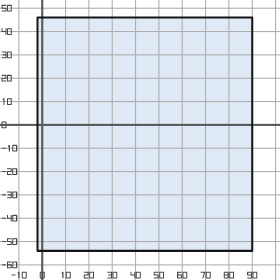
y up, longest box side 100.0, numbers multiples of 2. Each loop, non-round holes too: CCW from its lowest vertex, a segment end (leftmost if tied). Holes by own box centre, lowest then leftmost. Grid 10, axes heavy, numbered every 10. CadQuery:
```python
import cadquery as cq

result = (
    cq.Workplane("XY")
    .moveTo(-2.0, -54.0)
    .lineTo(90.0, -54.0)
    .lineTo(90.0, 46.0)
    .lineTo(-2.0, 46.0)
    .close()
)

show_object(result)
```